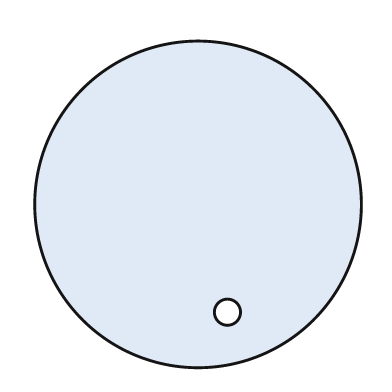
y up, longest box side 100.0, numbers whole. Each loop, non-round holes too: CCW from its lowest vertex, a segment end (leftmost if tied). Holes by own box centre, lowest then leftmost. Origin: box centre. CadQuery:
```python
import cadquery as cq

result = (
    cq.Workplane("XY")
    .moveTo(0.0, 0.0)
    .circle(50.0)
    .moveTo(9.0, -33.0)
    .circle(4.0)
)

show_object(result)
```